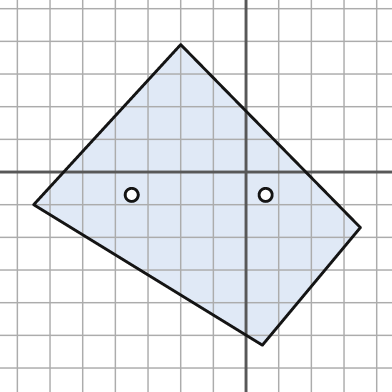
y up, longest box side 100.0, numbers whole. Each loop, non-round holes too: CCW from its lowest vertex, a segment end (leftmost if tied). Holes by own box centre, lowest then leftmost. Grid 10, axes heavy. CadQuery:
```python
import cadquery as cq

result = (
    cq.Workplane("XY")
    .moveTo(5.0, -53.0)
    .lineTo(35.0, -17.0)
    .lineTo(-20.0, 39.0)
    .lineTo(-65.0, -10.0)
    .close()
    .moveTo(-35.0, -7.0)
    .circle(2.0)
    .moveTo(6.0, -7.0)
    .circle(2.0)
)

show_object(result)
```